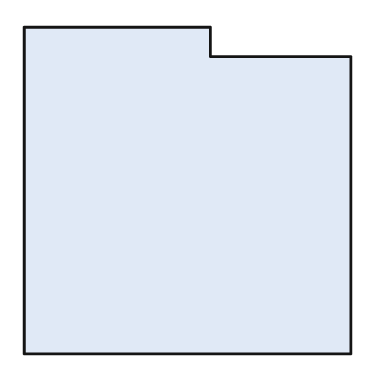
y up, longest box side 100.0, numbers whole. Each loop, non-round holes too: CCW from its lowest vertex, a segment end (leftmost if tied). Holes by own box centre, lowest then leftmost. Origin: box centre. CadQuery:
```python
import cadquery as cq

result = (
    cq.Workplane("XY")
    .moveTo(-50.0, -50.0)
    .lineTo(50.0, -50.0)
    .lineTo(50.0, 41.0)
    .lineTo(7.0, 41.0)
    .lineTo(7.0, 50.0)
    .lineTo(-50.0, 50.0)
    .close()
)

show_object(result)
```